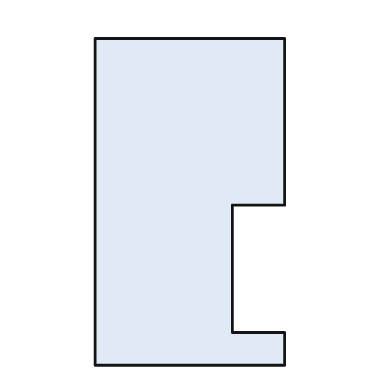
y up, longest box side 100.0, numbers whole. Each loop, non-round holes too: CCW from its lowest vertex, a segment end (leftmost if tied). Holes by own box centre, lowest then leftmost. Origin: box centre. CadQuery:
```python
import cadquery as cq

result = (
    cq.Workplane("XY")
    .moveTo(-29.0, -50.0)
    .lineTo(29.0, -50.0)
    .lineTo(29.0, -40.0)
    .lineTo(13.0, -40.0)
    .lineTo(13.0, -1.0)
    .lineTo(29.0, -1.0)
    .lineTo(29.0, 50.0)
    .lineTo(-29.0, 50.0)
    .close()
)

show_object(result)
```